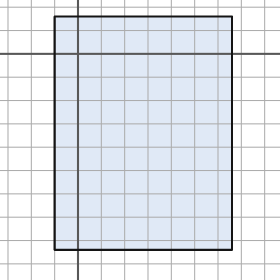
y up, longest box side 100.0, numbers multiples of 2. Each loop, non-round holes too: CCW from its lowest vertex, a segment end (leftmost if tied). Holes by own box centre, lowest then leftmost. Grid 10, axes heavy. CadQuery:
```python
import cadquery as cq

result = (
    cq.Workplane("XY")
    .moveTo(-10.0, -84.0)
    .lineTo(66.0, -84.0)
    .lineTo(66.0, 16.0)
    .lineTo(-10.0, 16.0)
    .close()
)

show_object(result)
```